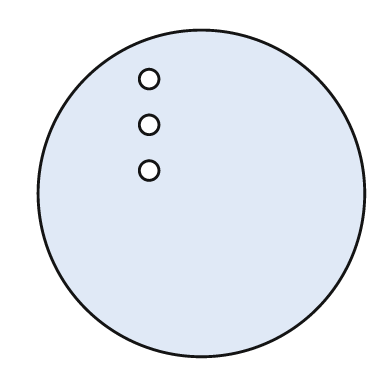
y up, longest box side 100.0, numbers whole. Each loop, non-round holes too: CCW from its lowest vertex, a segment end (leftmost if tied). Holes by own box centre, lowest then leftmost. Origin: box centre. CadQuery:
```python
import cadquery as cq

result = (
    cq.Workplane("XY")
    .moveTo(0.0, 0.0)
    .circle(50.0)
    .moveTo(-16.0, 7.0)
    .circle(3.0)
    .moveTo(-16.0, 21.0)
    .circle(3.0)
    .moveTo(-16.0, 35.0)
    .circle(3.0)
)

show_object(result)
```